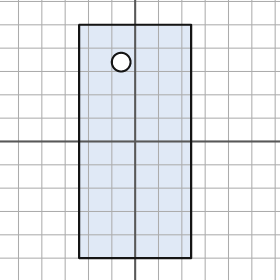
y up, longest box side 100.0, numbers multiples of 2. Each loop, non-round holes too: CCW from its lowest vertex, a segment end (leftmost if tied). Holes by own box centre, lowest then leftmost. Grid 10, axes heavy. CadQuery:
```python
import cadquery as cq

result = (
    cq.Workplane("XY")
    .moveTo(-24.0, -50.0)
    .lineTo(24.0, -50.0)
    .lineTo(24.0, 50.0)
    .lineTo(-24.0, 50.0)
    .close()
    .moveTo(-6.0, 34.0)
    .circle(4.0)
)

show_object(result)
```